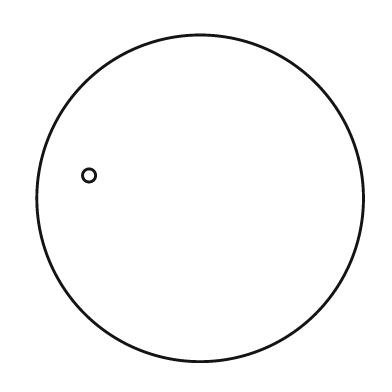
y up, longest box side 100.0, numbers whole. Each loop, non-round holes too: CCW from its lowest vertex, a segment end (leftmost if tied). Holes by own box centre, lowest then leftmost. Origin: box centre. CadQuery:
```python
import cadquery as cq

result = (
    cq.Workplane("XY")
    .moveTo(0.0, 0.0)
    .circle(50.0)
    .moveTo(-34.0, 7.0)
    .circle(2.0)
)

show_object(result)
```